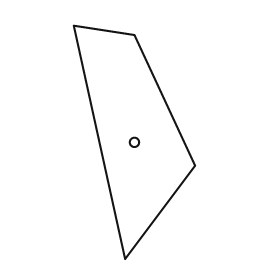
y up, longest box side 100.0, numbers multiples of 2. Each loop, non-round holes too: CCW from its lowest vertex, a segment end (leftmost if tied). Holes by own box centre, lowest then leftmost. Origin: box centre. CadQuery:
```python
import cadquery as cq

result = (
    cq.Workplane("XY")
    .moveTo(-4.0, -50.0)
    .lineTo(26.0, -10.0)
    .lineTo(0.0, 46.0)
    .lineTo(-26.0, 50.0)
    .close()
    .moveTo(0.0, 0.0)
    .circle(2.0)
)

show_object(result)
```